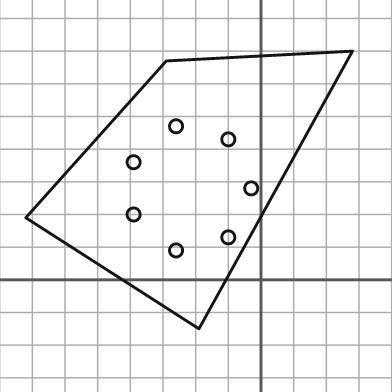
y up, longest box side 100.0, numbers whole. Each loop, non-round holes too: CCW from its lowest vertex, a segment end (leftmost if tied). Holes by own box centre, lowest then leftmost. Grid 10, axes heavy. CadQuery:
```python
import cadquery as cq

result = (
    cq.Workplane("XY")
    .moveTo(-19.0, -15.0)
    .lineTo(28.0, 70.0)
    .lineTo(-29.0, 67.0)
    .lineTo(-72.0, 19.0)
    .close()
    .moveTo(-26.0, 9.0)
    .circle(2.0)
    .moveTo(-10.0, 13.0)
    .circle(2.0)
    .moveTo(-39.0, 20.0)
    .circle(2.0)
    .moveTo(-3.0, 28.0)
    .circle(2.0)
    .moveTo(-39.0, 36.0)
    .circle(2.0)
    .moveTo(-10.0, 43.0)
    .circle(2.0)
    .moveTo(-26.0, 47.0)
    .circle(2.0)
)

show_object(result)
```